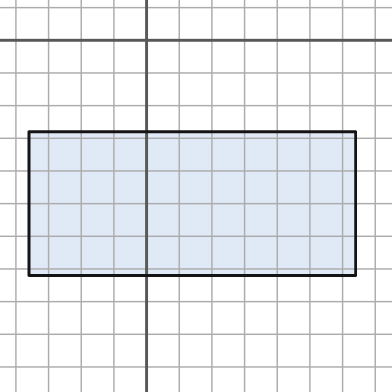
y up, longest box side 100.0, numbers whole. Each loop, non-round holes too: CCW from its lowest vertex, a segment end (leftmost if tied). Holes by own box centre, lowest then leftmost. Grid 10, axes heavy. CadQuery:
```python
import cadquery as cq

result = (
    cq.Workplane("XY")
    .moveTo(-36.0, -72.0)
    .lineTo(64.0, -72.0)
    .lineTo(64.0, -28.0)
    .lineTo(-36.0, -28.0)
    .close()
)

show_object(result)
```